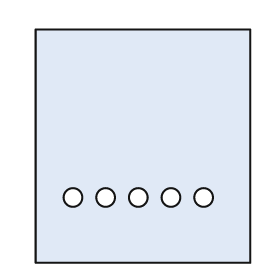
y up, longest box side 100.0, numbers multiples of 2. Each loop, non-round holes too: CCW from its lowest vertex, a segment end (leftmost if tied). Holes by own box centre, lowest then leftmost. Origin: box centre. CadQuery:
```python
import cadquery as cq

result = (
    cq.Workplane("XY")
    .moveTo(-46.0, -50.0)
    .lineTo(46.0, -50.0)
    .lineTo(46.0, 50.0)
    .lineTo(-46.0, 50.0)
    .close()
    .moveTo(-30.0, -22.0)
    .circle(4.0)
    .moveTo(-16.0, -22.0)
    .circle(4.0)
    .moveTo(-2.0, -22.0)
    .circle(4.0)
    .moveTo(12.0, -22.0)
    .circle(4.0)
    .moveTo(26.0, -22.0)
    .circle(4.0)
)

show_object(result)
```